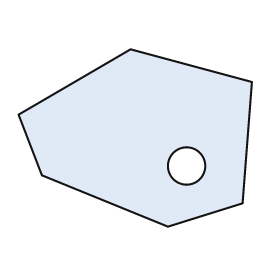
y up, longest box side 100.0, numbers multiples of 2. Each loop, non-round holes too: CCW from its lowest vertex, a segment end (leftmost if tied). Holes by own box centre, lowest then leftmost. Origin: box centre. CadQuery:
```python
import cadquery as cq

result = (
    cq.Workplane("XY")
    .moveTo(14.0, -38.0)
    .lineTo(46.0, -28.0)
    .lineTo(50.0, 24.0)
    .lineTo(-2.0, 38.0)
    .lineTo(-50.0, 10.0)
    .lineTo(-40.0, -16.0)
    .close()
    .moveTo(22.0, -12.0)
    .circle(8.0)
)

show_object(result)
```